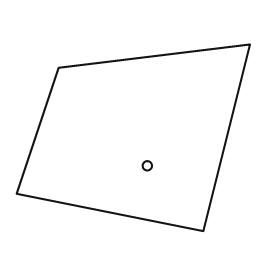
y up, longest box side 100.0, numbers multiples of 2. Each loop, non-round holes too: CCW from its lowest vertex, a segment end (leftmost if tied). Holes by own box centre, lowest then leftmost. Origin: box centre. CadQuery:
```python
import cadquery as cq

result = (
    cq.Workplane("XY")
    .moveTo(30.0, -40.0)
    .lineTo(50.0, 40.0)
    .lineTo(-32.0, 30.0)
    .lineTo(-50.0, -24.0)
    .close()
    .moveTo(6.0, -12.0)
    .circle(2.0)
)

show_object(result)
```